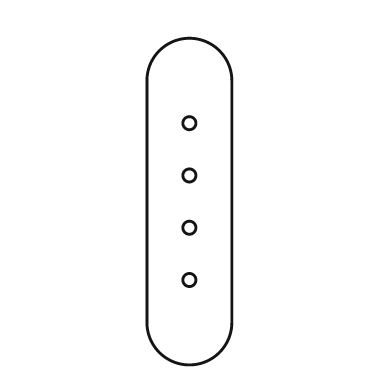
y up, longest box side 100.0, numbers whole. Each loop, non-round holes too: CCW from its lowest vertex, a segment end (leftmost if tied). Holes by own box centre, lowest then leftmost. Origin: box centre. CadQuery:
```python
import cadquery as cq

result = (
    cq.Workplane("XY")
    .moveTo(-13.0, -37.0)
    .threePointArc((0.0, -50.0), (13.0, -37.0))
    .lineTo(13.0, 37.0)
    .threePointArc((0.0, 50.0), (-13.0, 37.0))
    .close()
    .moveTo(0.0, -24.0)
    .circle(2.0)
    .moveTo(0.0, -8.0)
    .circle(2.0)
    .moveTo(0.0, 8.0)
    .circle(2.0)
    .moveTo(0.0, 24.0)
    .circle(2.0)
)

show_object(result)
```